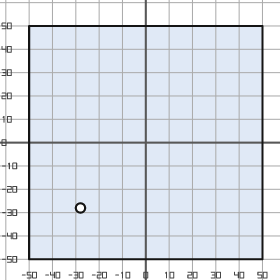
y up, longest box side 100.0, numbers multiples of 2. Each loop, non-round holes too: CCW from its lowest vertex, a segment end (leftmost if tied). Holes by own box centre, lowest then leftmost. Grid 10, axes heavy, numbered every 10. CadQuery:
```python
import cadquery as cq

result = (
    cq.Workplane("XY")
    .moveTo(-50.0, -50.0)
    .lineTo(50.0, -50.0)
    .lineTo(50.0, 50.0)
    .lineTo(-50.0, 50.0)
    .close()
    .moveTo(-28.0, -28.0)
    .circle(2.0)
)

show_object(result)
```